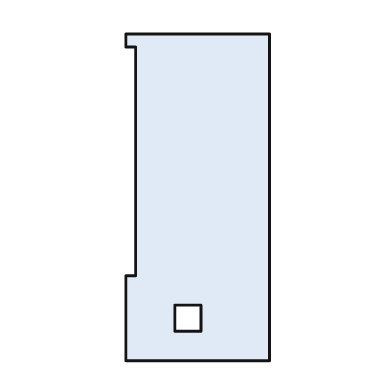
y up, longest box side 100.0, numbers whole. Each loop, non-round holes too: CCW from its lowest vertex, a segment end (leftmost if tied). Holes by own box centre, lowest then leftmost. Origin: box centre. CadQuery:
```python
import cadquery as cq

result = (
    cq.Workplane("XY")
    .moveTo(-22.0, -50.0)
    .lineTo(22.0, -50.0)
    .lineTo(22.0, 50.0)
    .lineTo(-22.0, 50.0)
    .lineTo(-22.0, 46.0)
    .lineTo(-19.0, 46.0)
    .lineTo(-19.0, -24.0)
    .lineTo(-22.0, -24.0)
    .close()
    .moveTo(-7.0, -41.0)
    .lineTo(1.0, -41.0)
    .lineTo(1.0, -33.0)
    .lineTo(-7.0, -33.0)
    .close()
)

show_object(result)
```